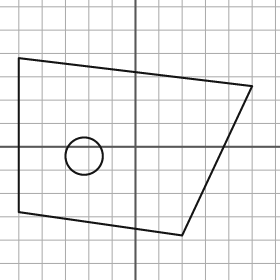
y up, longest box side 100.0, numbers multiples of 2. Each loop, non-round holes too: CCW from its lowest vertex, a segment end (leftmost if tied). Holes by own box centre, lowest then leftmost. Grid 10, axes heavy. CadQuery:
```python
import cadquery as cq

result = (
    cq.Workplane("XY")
    .moveTo(20.0, -38.0)
    .lineTo(50.0, 26.0)
    .lineTo(-50.0, 38.0)
    .lineTo(-50.0, -28.0)
    .close()
    .moveTo(-22.0, -4.0)
    .circle(8.0)
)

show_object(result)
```